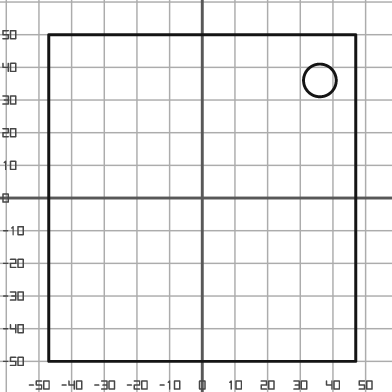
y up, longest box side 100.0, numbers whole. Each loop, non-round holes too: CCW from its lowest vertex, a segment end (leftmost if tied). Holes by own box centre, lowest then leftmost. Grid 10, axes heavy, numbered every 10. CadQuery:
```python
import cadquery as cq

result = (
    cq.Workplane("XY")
    .moveTo(-47.0, -50.0)
    .lineTo(47.0, -50.0)
    .lineTo(47.0, 50.0)
    .lineTo(-47.0, 50.0)
    .close()
    .moveTo(36.0, 36.0)
    .circle(5.0)
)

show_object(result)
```